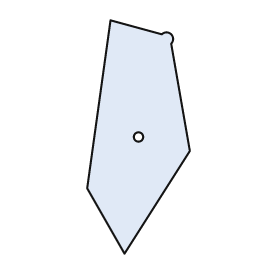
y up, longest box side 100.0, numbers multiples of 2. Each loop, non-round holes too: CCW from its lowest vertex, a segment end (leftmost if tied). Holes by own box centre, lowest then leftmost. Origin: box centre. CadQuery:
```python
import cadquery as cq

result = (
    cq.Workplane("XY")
    .moveTo(-6.0, -50.0)
    .lineTo(22.0, -6.0)
    .lineTo(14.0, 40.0)
    .threePointArc((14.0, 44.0), (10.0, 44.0))
    .lineTo(-12.0, 50.0)
    .lineTo(-22.0, -22.0)
    .close()
    .moveTo(0.0, 0.0)
    .circle(2.0)
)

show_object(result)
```